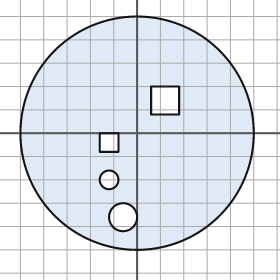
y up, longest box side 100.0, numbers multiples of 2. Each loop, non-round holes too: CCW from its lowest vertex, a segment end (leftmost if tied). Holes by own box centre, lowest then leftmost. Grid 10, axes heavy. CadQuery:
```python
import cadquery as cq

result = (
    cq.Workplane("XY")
    .moveTo(0.0, 0.0)
    .circle(50.0)
    .moveTo(-6.0, -36.0)
    .circle(6.0)
    .moveTo(-12.0, -20.0)
    .circle(4.0)
    .moveTo(-16.0, -8.0)
    .lineTo(-8.0, -8.0)
    .lineTo(-8.0, 0.0)
    .lineTo(-16.0, 0.0)
    .close()
    .moveTo(6.0, 8.0)
    .lineTo(18.0, 8.0)
    .lineTo(18.0, 20.0)
    .lineTo(6.0, 20.0)
    .close()
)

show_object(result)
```